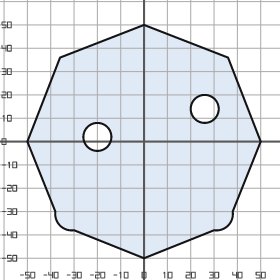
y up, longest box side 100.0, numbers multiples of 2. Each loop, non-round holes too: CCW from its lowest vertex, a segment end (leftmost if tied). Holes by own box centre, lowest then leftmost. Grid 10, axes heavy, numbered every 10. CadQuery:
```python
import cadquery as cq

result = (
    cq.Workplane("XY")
    .moveTo(0.0, -50.0)
    .lineTo(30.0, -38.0)
    .threePointArc((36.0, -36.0), (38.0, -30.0))
    .lineTo(50.0, 0.0)
    .lineTo(36.0, 36.0)
    .lineTo(0.0, 50.0)
    .lineTo(-36.0, 36.0)
    .lineTo(-50.0, 0.0)
    .lineTo(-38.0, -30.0)
    .threePointArc((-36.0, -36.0), (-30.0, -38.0))
    .close()
    .moveTo(-20.0, 2.0)
    .circle(6.0)
    .moveTo(26.0, 14.0)
    .circle(6.0)
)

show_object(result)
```